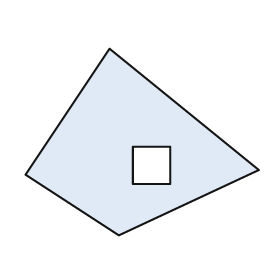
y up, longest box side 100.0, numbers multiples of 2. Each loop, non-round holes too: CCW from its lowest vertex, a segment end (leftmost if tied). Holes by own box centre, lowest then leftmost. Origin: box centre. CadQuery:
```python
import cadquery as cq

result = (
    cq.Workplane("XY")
    .moveTo(-10.0, -40.0)
    .lineTo(50.0, -12.0)
    .lineTo(-14.0, 40.0)
    .lineTo(-50.0, -14.0)
    .close()
    .moveTo(-4.0, -18.0)
    .lineTo(12.0, -18.0)
    .lineTo(12.0, -2.0)
    .lineTo(-4.0, -2.0)
    .close()
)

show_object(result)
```